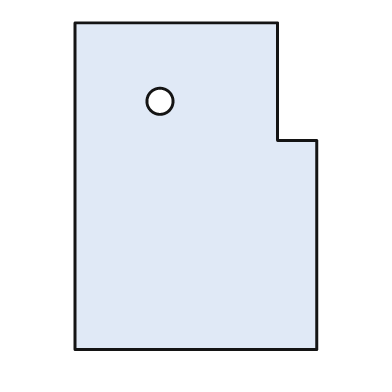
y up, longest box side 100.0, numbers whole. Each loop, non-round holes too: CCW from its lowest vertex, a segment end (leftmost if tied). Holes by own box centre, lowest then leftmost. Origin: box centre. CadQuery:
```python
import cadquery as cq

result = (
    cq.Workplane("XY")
    .moveTo(-37.0, -50.0)
    .lineTo(37.0, -50.0)
    .lineTo(37.0, 14.0)
    .lineTo(25.0, 14.0)
    .lineTo(25.0, 50.0)
    .lineTo(-37.0, 50.0)
    .close()
    .moveTo(-11.0, 26.0)
    .circle(4.0)
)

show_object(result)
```